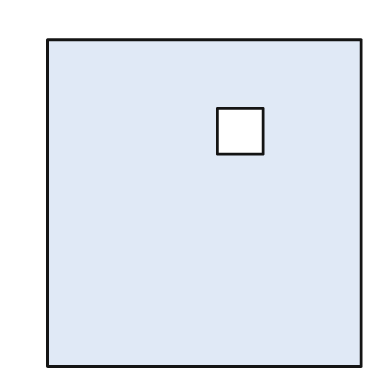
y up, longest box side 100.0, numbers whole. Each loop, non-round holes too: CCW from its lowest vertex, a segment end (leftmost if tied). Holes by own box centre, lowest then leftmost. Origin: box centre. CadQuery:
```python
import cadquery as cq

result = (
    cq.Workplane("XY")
    .moveTo(-48.0, -50.0)
    .lineTo(48.0, -50.0)
    .lineTo(48.0, 50.0)
    .lineTo(-48.0, 50.0)
    .close()
    .moveTo(4.0, 15.0)
    .lineTo(18.0, 15.0)
    .lineTo(18.0, 29.0)
    .lineTo(4.0, 29.0)
    .close()
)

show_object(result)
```